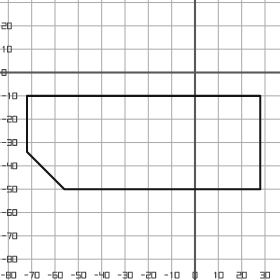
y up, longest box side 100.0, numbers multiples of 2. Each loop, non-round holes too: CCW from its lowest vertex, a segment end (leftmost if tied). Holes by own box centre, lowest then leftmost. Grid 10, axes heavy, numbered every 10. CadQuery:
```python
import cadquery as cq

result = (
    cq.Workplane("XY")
    .moveTo(-56.0, -50.0)
    .lineTo(28.0, -50.0)
    .lineTo(28.0, -10.0)
    .lineTo(-72.0, -10.0)
    .lineTo(-72.0, -34.0)
    .close()
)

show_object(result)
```